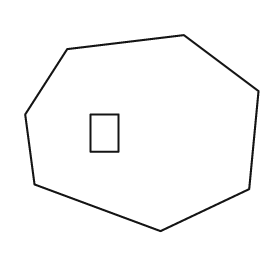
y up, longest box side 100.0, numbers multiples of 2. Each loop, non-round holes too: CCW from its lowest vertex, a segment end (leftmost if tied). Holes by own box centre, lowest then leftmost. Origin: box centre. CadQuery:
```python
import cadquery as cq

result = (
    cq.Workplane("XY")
    .moveTo(8.0, -42.0)
    .lineTo(46.0, -24.0)
    .lineTo(50.0, 18.0)
    .lineTo(18.0, 42.0)
    .lineTo(-32.0, 36.0)
    .lineTo(-50.0, 8.0)
    .lineTo(-46.0, -22.0)
    .close()
    .moveTo(-22.0, -8.0)
    .lineTo(-10.0, -8.0)
    .lineTo(-10.0, 8.0)
    .lineTo(-22.0, 8.0)
    .close()
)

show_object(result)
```